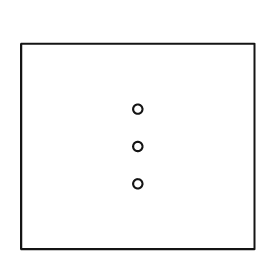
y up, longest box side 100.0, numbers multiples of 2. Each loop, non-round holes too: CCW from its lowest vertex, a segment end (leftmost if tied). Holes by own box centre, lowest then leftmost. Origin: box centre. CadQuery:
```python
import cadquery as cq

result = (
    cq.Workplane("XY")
    .moveTo(-50.0, -44.0)
    .lineTo(50.0, -44.0)
    .lineTo(50.0, 44.0)
    .lineTo(-50.0, 44.0)
    .close()
    .moveTo(0.0, -16.0)
    .circle(2.0)
    .moveTo(0.0, 0.0)
    .circle(2.0)
    .moveTo(0.0, 16.0)
    .circle(2.0)
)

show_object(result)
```